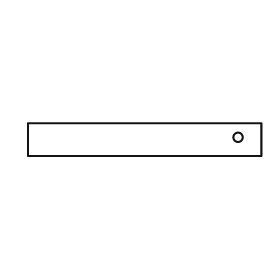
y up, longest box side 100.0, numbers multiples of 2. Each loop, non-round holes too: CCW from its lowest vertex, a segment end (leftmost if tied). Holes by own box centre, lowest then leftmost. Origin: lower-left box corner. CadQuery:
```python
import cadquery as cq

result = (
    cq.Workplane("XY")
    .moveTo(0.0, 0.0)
    .lineTo(100.0, 0.0)
    .lineTo(100.0, 14.0)
    .lineTo(0.0, 14.0)
    .close()
    .moveTo(90.0, 8.0)
    .circle(2.0)
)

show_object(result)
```